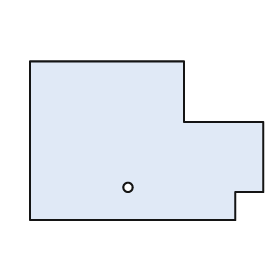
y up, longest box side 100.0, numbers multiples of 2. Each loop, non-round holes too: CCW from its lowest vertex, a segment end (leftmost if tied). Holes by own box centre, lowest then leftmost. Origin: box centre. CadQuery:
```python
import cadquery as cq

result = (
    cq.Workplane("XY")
    .moveTo(-50.0, -34.0)
    .lineTo(38.0, -34.0)
    .lineTo(38.0, -22.0)
    .lineTo(50.0, -22.0)
    .lineTo(50.0, 8.0)
    .lineTo(16.0, 8.0)
    .lineTo(16.0, 34.0)
    .lineTo(-50.0, 34.0)
    .close()
    .moveTo(-8.0, -20.0)
    .circle(2.0)
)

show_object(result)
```